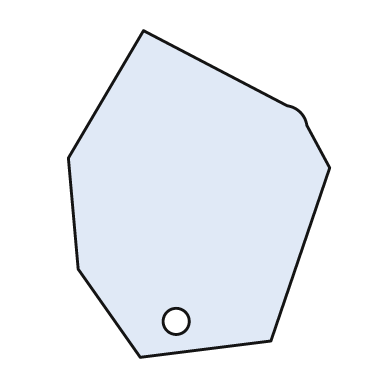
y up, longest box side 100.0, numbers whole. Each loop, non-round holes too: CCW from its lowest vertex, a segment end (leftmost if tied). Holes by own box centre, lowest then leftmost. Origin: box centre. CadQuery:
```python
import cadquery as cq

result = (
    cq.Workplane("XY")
    .moveTo(-18.0, -50.0)
    .lineTo(22.0, -45.0)
    .lineTo(40.0, 8.0)
    .lineTo(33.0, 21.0)
    .threePointArc((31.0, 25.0), (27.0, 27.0))
    .lineTo(-17.0, 50.0)
    .lineTo(-40.0, 11.0)
    .lineTo(-37.0, -23.0)
    .close()
    .moveTo(-7.0, -39.0)
    .circle(4.0)
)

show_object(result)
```